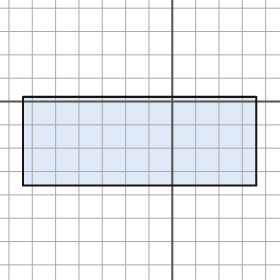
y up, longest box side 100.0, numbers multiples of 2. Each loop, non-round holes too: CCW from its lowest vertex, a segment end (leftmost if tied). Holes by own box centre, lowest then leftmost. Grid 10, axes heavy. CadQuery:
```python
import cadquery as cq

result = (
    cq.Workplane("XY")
    .moveTo(-64.0, -36.0)
    .lineTo(36.0, -36.0)
    .lineTo(36.0, 2.0)
    .lineTo(-64.0, 2.0)
    .close()
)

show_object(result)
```